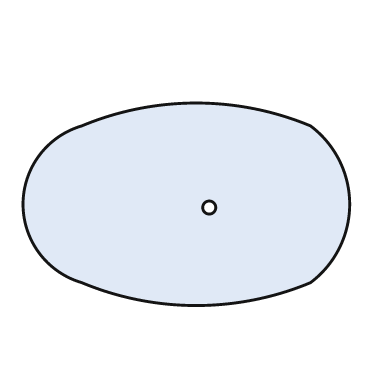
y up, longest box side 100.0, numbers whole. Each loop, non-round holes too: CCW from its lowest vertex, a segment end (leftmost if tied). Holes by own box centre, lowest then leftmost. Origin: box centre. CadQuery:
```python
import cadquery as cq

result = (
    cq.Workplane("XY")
    .moveTo(-32.0, -24.0)
    .threePointArc((3.0, -31.0), (38.0, -24.0))
    .threePointArc((50.0, 0.0), (38.0, 24.0))
    .threePointArc((3.0, 31.0), (-32.0, 24.0))
    .threePointArc((-50.0, 0.0), (-32.0, -24.0))
    .close()
    .moveTo(7.0, -1.0)
    .circle(2.0)
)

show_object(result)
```